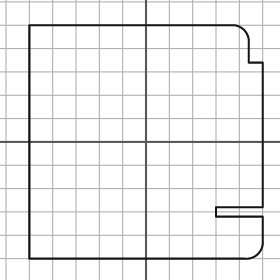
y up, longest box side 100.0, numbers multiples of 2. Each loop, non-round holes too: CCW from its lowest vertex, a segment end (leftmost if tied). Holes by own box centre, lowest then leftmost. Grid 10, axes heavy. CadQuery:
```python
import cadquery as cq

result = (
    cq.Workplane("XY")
    .moveTo(-50.0, -50.0)
    .lineTo(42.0, -50.0)
    .threePointArc((48.0, -48.0), (50.0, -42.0))
    .lineTo(50.0, -32.0)
    .lineTo(30.0, -32.0)
    .lineTo(30.0, -28.0)
    .lineTo(50.0, -28.0)
    .lineTo(50.0, 34.0)
    .lineTo(44.0, 34.0)
    .lineTo(44.0, 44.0)
    .threePointArc((42.0, 48.0), (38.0, 50.0))
    .lineTo(-50.0, 50.0)
    .close()
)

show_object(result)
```